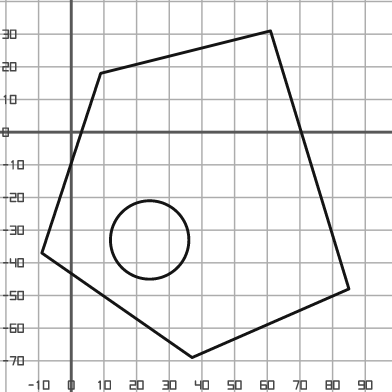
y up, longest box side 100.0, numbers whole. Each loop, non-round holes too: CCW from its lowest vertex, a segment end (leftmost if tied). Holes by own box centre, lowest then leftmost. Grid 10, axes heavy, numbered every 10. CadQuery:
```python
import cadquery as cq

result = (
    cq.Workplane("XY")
    .moveTo(37.0, -69.0)
    .lineTo(85.0, -48.0)
    .lineTo(61.0, 31.0)
    .lineTo(9.0, 18.0)
    .lineTo(-9.0, -37.0)
    .close()
    .moveTo(24.0, -33.0)
    .circle(12.0)
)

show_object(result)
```